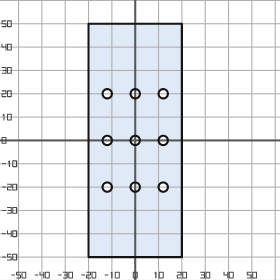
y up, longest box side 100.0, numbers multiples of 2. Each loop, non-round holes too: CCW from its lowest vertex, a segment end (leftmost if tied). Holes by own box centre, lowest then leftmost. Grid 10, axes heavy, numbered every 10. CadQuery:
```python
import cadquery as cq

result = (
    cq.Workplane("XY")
    .moveTo(-20.0, -50.0)
    .lineTo(20.0, -50.0)
    .lineTo(20.0, 50.0)
    .lineTo(-20.0, 50.0)
    .close()
    .moveTo(-12.0, -20.0)
    .circle(2.0)
    .moveTo(0.0, -20.0)
    .circle(2.0)
    .moveTo(12.0, -20.0)
    .circle(2.0)
    .moveTo(-12.0, 0.0)
    .circle(2.0)
    .moveTo(0.0, 0.0)
    .circle(2.0)
    .moveTo(12.0, 0.0)
    .circle(2.0)
    .moveTo(-12.0, 20.0)
    .circle(2.0)
    .moveTo(0.0, 20.0)
    .circle(2.0)
    .moveTo(12.0, 20.0)
    .circle(2.0)
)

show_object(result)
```